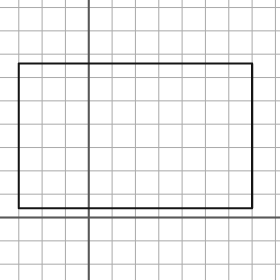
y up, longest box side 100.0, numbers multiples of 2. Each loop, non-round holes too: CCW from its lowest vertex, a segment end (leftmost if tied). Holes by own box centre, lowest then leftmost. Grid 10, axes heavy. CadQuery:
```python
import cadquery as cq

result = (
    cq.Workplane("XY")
    .moveTo(-30.0, 4.0)
    .lineTo(70.0, 4.0)
    .lineTo(70.0, 66.0)
    .lineTo(-30.0, 66.0)
    .close()
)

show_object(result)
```